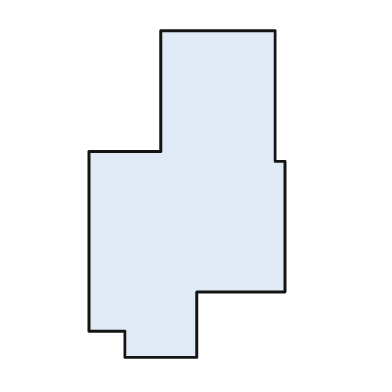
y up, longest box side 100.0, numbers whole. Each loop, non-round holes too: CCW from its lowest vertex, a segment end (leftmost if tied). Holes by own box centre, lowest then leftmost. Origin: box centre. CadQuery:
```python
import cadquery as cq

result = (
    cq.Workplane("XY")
    .moveTo(-19.0, -50.0)
    .lineTo(3.0, -50.0)
    .lineTo(3.0, -30.0)
    .lineTo(30.0, -30.0)
    .lineTo(30.0, 10.0)
    .lineTo(27.0, 10.0)
    .lineTo(27.0, 50.0)
    .lineTo(-8.0, 50.0)
    .lineTo(-8.0, 13.0)
    .lineTo(-30.0, 13.0)
    .lineTo(-30.0, -42.0)
    .lineTo(-19.0, -42.0)
    .close()
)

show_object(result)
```